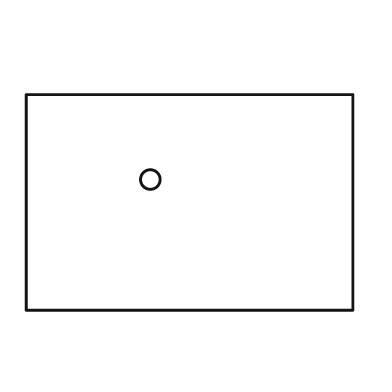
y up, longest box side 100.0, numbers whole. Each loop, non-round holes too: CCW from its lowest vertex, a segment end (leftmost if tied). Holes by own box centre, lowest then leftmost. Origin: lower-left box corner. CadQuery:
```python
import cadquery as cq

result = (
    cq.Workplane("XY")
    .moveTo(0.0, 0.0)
    .lineTo(100.0, 0.0)
    .lineTo(100.0, 66.0)
    .lineTo(0.0, 66.0)
    .close()
    .moveTo(38.0, 40.0)
    .circle(3.0)
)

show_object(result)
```